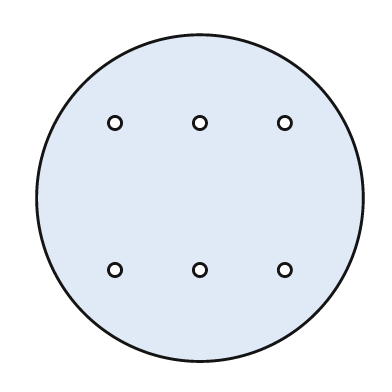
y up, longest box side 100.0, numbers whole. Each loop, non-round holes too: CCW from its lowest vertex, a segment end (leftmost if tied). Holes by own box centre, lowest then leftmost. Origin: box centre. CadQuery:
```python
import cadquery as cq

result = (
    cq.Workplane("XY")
    .moveTo(0.0, 0.0)
    .circle(50.0)
    .moveTo(-26.0, -22.0)
    .circle(2.0)
    .moveTo(0.0, -22.0)
    .circle(2.0)
    .moveTo(26.0, -22.0)
    .circle(2.0)
    .moveTo(-26.0, 23.0)
    .circle(2.0)
    .moveTo(0.0, 23.0)
    .circle(2.0)
    .moveTo(26.0, 23.0)
    .circle(2.0)
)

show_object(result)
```